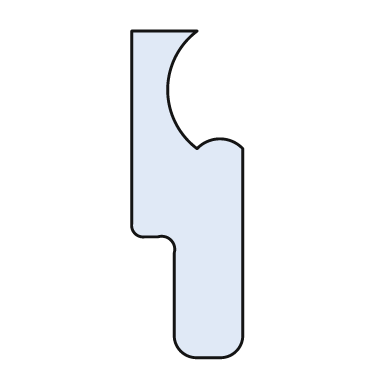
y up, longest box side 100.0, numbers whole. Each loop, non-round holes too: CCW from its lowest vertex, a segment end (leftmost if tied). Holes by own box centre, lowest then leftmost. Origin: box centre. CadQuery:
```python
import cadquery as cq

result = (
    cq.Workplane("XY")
    .moveTo(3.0, -50.0)
    .lineTo(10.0, -50.0)
    .threePointArc((15.0, -48.0), (17.0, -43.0))
    .lineTo(17.0, 14.0)
    .threePointArc((10.0, 17.0), (3.0, 14.0))
    .threePointArc((-6.0, 32.0), (3.0, 50.0))
    .lineTo(-17.0, 50.0)
    .lineTo(-17.0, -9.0)
    .threePointArc((-16.0, -12.0), (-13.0, -13.0))
    .lineTo(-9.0, -13.0)
    .threePointArc((-5.0, -14.0), (-4.0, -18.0))
    .lineTo(-4.0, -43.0)
    .threePointArc((-2.0, -48.0), (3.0, -50.0))
    .close()
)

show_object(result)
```